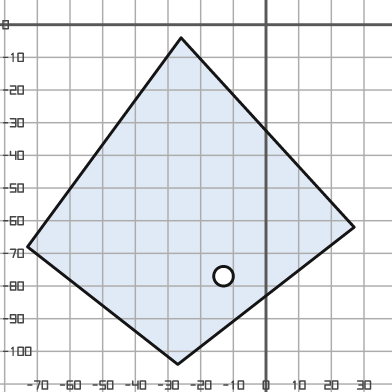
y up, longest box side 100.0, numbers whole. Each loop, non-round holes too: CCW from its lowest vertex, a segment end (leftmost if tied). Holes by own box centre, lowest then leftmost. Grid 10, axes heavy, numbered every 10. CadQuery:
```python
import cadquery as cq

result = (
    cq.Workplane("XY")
    .moveTo(-27.0, -104.0)
    .lineTo(27.0, -62.0)
    .lineTo(-26.0, -4.0)
    .lineTo(-73.0, -68.0)
    .close()
    .moveTo(-13.0, -77.0)
    .circle(3.0)
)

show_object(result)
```